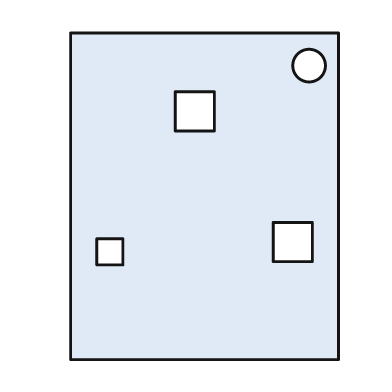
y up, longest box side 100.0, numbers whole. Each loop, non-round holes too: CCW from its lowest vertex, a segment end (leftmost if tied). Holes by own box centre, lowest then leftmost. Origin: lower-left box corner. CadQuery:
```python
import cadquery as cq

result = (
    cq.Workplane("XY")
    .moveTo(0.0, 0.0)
    .lineTo(82.0, 0.0)
    .lineTo(82.0, 100.0)
    .lineTo(0.0, 100.0)
    .close()
    .moveTo(8.0, 29.0)
    .lineTo(16.0, 29.0)
    .lineTo(16.0, 37.0)
    .lineTo(8.0, 37.0)
    .close()
    .moveTo(62.0, 30.0)
    .lineTo(74.0, 30.0)
    .lineTo(74.0, 42.0)
    .lineTo(62.0, 42.0)
    .close()
    .moveTo(32.0, 70.0)
    .lineTo(44.0, 70.0)
    .lineTo(44.0, 82.0)
    .lineTo(32.0, 82.0)
    .close()
    .moveTo(73.0, 90.0)
    .circle(5.0)
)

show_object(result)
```